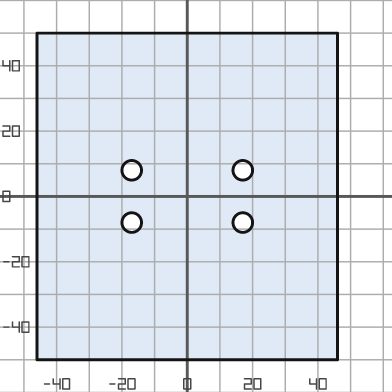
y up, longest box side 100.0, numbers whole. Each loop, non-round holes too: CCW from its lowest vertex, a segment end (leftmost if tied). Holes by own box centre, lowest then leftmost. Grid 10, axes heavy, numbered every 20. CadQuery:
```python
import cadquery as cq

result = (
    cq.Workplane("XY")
    .moveTo(-46.0, -50.0)
    .lineTo(46.0, -50.0)
    .lineTo(46.0, 50.0)
    .lineTo(-46.0, 50.0)
    .close()
    .moveTo(-17.0, -8.0)
    .circle(3.0)
    .moveTo(17.0, -8.0)
    .circle(3.0)
    .moveTo(-17.0, 8.0)
    .circle(3.0)
    .moveTo(17.0, 8.0)
    .circle(3.0)
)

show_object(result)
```